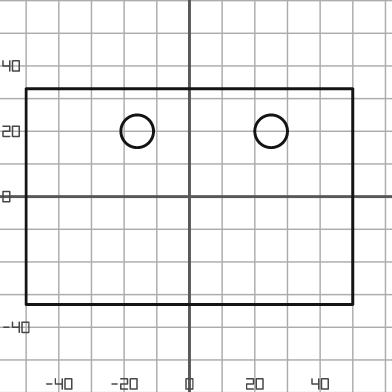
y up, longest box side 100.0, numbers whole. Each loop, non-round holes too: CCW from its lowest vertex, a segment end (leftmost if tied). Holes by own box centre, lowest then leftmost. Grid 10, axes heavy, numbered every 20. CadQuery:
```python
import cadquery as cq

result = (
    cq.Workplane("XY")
    .moveTo(-50.0, -33.0)
    .lineTo(50.0, -33.0)
    .lineTo(50.0, 33.0)
    .lineTo(-50.0, 33.0)
    .close()
    .moveTo(-16.0, 20.0)
    .circle(5.0)
    .moveTo(25.0, 20.0)
    .circle(5.0)
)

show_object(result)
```